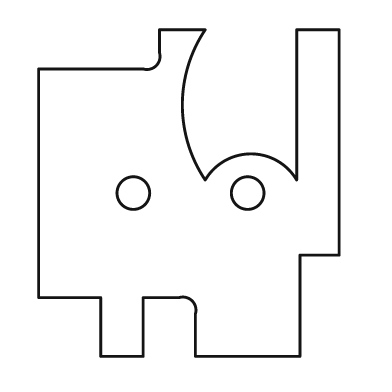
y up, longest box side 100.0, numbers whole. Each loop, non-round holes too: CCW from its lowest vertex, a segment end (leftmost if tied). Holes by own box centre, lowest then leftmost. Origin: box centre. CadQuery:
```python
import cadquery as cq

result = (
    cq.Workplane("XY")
    .moveTo(-27.0, -50.0)
    .lineTo(-14.0, -50.0)
    .lineTo(-14.0, -32.0)
    .lineTo(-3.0, -32.0)
    .threePointArc((1.0, -33.0), (2.0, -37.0))
    .lineTo(2.0, -50.0)
    .lineTo(34.0, -50.0)
    .lineTo(34.0, -19.0)
    .lineTo(46.0, -19.0)
    .lineTo(46.0, 50.0)
    .lineTo(33.0, 50.0)
    .lineTo(33.0, 4.0)
    .threePointArc((19.0, 12.0), (5.0, 4.0))
    .threePointArc((-2.0, 27.0), (5.0, 50.0))
    .lineTo(-9.0, 50.0)
    .lineTo(-9.0, 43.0)
    .threePointArc((-10.0, 39.0), (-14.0, 38.0))
    .lineTo(-46.0, 38.0)
    .lineTo(-46.0, -32.0)
    .lineTo(-27.0, -32.0)
    .close()
    .moveTo(-17.0, 0.0)
    .circle(5.0)
    .moveTo(18.0, 0.0)
    .circle(5.0)
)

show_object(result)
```